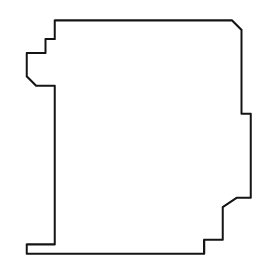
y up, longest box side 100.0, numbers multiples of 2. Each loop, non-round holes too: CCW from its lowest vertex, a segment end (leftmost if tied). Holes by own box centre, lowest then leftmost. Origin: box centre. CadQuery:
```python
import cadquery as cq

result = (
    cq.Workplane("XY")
    .moveTo(-48.0, -50.0)
    .lineTo(28.0, -50.0)
    .lineTo(28.0, -44.0)
    .lineTo(36.0, -44.0)
    .lineTo(36.0, -30.0)
    .lineTo(42.0, -26.0)
    .lineTo(48.0, -26.0)
    .lineTo(48.0, 10.0)
    .lineTo(44.0, 10.0)
    .lineTo(44.0, 46.0)
    .lineTo(40.0, 50.0)
    .lineTo(-36.0, 50.0)
    .lineTo(-36.0, 42.0)
    .lineTo(-40.0, 42.0)
    .lineTo(-40.0, 36.0)
    .lineTo(-48.0, 36.0)
    .lineTo(-48.0, 26.0)
    .lineTo(-44.0, 22.0)
    .lineTo(-36.0, 22.0)
    .lineTo(-36.0, -46.0)
    .lineTo(-48.0, -46.0)
    .close()
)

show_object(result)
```